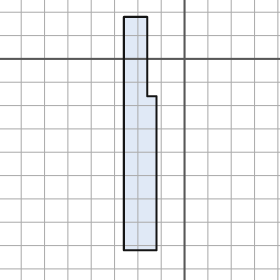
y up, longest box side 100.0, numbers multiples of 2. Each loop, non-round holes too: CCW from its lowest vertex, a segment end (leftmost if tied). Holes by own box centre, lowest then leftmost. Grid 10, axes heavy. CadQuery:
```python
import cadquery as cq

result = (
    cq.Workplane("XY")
    .moveTo(-26.0, -82.0)
    .lineTo(-12.0, -82.0)
    .lineTo(-12.0, -16.0)
    .lineTo(-16.0, -16.0)
    .lineTo(-16.0, 18.0)
    .lineTo(-26.0, 18.0)
    .close()
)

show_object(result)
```